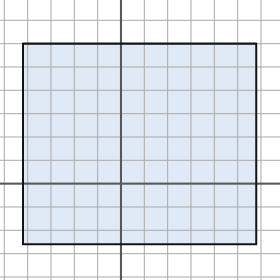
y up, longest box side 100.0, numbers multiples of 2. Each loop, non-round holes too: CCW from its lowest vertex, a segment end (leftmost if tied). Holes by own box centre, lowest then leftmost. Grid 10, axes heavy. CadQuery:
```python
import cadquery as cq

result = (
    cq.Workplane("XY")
    .moveTo(-42.0, -26.0)
    .lineTo(58.0, -26.0)
    .lineTo(58.0, 60.0)
    .lineTo(-42.0, 60.0)
    .close()
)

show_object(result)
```